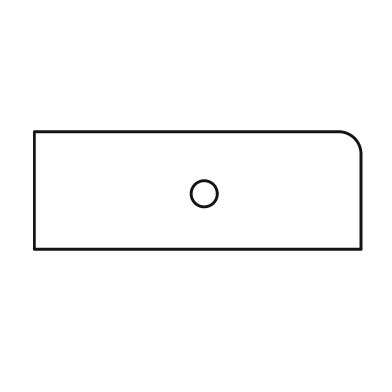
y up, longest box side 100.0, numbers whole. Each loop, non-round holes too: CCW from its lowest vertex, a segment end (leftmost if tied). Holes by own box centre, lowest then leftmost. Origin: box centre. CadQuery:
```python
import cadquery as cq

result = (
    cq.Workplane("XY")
    .moveTo(-50.0, -18.0)
    .lineTo(50.0, -18.0)
    .lineTo(50.0, 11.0)
    .threePointArc((48.0, 16.0), (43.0, 18.0))
    .lineTo(-50.0, 18.0)
    .close()
    .moveTo(2.0, -1.0)
    .circle(4.0)
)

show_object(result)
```